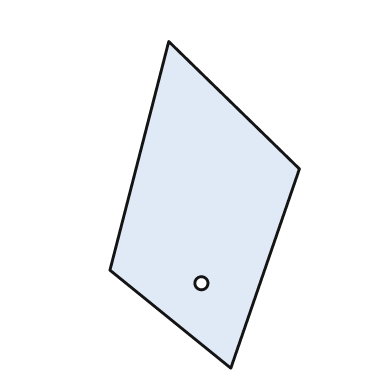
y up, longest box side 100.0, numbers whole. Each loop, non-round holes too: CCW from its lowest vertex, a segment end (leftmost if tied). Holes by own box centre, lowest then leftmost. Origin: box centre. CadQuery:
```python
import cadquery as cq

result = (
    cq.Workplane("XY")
    .moveTo(8.0, -50.0)
    .lineTo(29.0, 11.0)
    .lineTo(-11.0, 50.0)
    .lineTo(-29.0, -20.0)
    .close()
    .moveTo(-1.0, -24.0)
    .circle(2.0)
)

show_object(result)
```